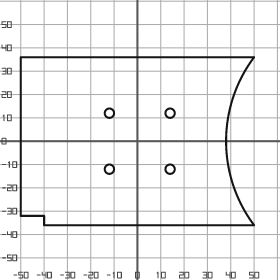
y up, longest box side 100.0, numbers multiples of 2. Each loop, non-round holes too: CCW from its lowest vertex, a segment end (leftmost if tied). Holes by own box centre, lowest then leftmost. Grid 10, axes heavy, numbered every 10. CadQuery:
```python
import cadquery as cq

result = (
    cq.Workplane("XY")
    .moveTo(-40.0, -36.0)
    .lineTo(50.0, -36.0)
    .threePointArc((38.0, 0.0), (50.0, 36.0))
    .lineTo(-50.0, 36.0)
    .lineTo(-50.0, -32.0)
    .lineTo(-40.0, -32.0)
    .close()
    .moveTo(-12.0, -12.0)
    .circle(2.0)
    .moveTo(14.0, -12.0)
    .circle(2.0)
    .moveTo(-12.0, 12.0)
    .circle(2.0)
    .moveTo(14.0, 12.0)
    .circle(2.0)
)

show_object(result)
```